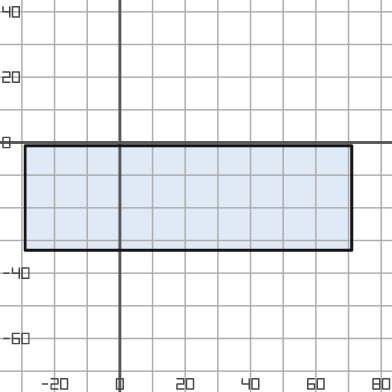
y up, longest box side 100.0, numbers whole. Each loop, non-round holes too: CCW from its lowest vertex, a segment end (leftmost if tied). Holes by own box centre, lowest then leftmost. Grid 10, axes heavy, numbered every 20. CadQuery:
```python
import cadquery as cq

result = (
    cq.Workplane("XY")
    .moveTo(-29.0, -33.0)
    .lineTo(71.0, -33.0)
    .lineTo(71.0, -1.0)
    .lineTo(-29.0, -1.0)
    .close()
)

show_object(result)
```